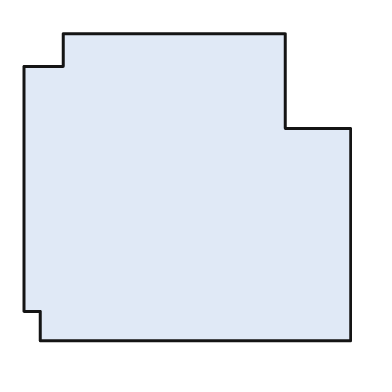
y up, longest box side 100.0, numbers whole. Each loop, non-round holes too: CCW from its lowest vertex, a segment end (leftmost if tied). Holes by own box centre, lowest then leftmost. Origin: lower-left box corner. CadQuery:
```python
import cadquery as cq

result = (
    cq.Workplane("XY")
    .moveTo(5.0, 0.0)
    .lineTo(100.0, 0.0)
    .lineTo(100.0, 65.0)
    .lineTo(80.0, 65.0)
    .lineTo(80.0, 94.0)
    .lineTo(12.0, 94.0)
    .lineTo(12.0, 84.0)
    .lineTo(0.0, 84.0)
    .lineTo(0.0, 9.0)
    .lineTo(5.0, 9.0)
    .close()
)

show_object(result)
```